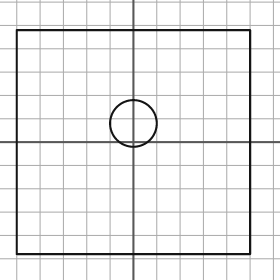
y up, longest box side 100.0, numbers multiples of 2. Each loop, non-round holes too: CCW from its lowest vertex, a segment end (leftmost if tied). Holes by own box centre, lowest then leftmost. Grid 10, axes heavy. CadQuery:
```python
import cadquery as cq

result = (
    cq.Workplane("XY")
    .moveTo(-50.0, -48.0)
    .lineTo(50.0, -48.0)
    .lineTo(50.0, 48.0)
    .lineTo(-50.0, 48.0)
    .close()
    .moveTo(0.0, 8.0)
    .circle(10.0)
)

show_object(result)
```